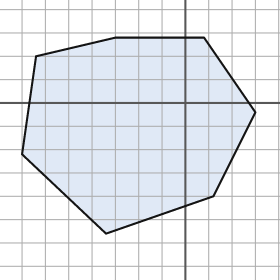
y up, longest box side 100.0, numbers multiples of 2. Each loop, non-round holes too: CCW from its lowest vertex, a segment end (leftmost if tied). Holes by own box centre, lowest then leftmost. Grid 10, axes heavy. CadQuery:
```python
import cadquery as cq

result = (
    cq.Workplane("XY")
    .moveTo(-34.0, -56.0)
    .lineTo(12.0, -40.0)
    .lineTo(30.0, -4.0)
    .lineTo(8.0, 28.0)
    .lineTo(-30.0, 28.0)
    .lineTo(-64.0, 20.0)
    .lineTo(-70.0, -22.0)
    .close()
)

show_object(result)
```